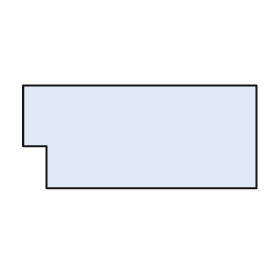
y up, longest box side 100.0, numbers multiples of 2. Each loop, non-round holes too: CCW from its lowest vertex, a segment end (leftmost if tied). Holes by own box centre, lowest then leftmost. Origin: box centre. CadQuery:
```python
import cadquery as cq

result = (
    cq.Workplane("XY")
    .moveTo(-40.0, -22.0)
    .lineTo(50.0, -22.0)
    .lineTo(50.0, 22.0)
    .lineTo(-50.0, 22.0)
    .lineTo(-50.0, -4.0)
    .lineTo(-40.0, -4.0)
    .close()
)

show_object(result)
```